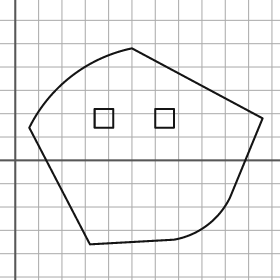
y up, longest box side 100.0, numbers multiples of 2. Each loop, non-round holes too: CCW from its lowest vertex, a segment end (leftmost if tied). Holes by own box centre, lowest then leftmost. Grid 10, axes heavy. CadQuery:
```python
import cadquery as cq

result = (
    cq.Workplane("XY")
    .moveTo(32.0, -36.0)
    .lineTo(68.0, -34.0)
    .threePointArc((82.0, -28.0), (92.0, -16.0))
    .lineTo(106.0, 18.0)
    .lineTo(50.0, 48.0)
    .threePointArc((24.0, 36.0), (6.0, 14.0))
    .close()
    .moveTo(34.0, 14.0)
    .lineTo(42.0, 14.0)
    .lineTo(42.0, 22.0)
    .lineTo(34.0, 22.0)
    .close()
    .moveTo(60.0, 14.0)
    .lineTo(68.0, 14.0)
    .lineTo(68.0, 22.0)
    .lineTo(60.0, 22.0)
    .close()
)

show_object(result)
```